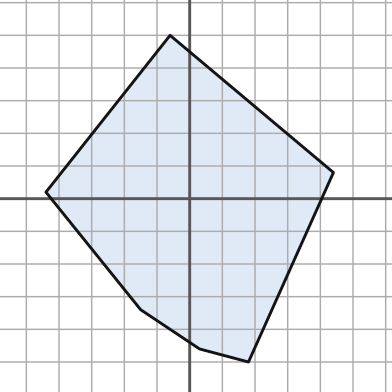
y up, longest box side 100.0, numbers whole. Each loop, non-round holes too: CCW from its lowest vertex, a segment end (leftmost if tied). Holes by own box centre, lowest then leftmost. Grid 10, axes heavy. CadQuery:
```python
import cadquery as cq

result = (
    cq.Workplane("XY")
    .moveTo(18.0, -50.0)
    .lineTo(44.0, 8.0)
    .lineTo(-6.0, 50.0)
    .lineTo(-44.0, 2.0)
    .lineTo(-15.0, -34.0)
    .lineTo(3.0, -46.0)
    .close()
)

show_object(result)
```